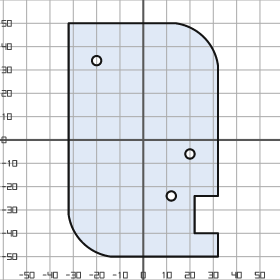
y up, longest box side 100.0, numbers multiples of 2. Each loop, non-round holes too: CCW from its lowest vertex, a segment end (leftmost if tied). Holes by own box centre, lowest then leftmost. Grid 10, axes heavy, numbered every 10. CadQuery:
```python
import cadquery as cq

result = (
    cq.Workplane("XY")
    .moveTo(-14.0, -50.0)
    .lineTo(32.0, -50.0)
    .lineTo(32.0, -40.0)
    .lineTo(22.0, -40.0)
    .lineTo(22.0, -24.0)
    .lineTo(32.0, -24.0)
    .lineTo(32.0, 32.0)
    .threePointArc((26.0, 44.0), (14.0, 50.0))
    .lineTo(-32.0, 50.0)
    .lineTo(-32.0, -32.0)
    .threePointArc((-26.0, -44.0), (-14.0, -50.0))
    .close()
    .moveTo(12.0, -24.0)
    .circle(2.0)
    .moveTo(20.0, -6.0)
    .circle(2.0)
    .moveTo(-20.0, 34.0)
    .circle(2.0)
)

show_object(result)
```